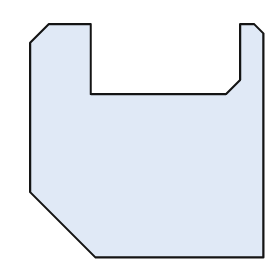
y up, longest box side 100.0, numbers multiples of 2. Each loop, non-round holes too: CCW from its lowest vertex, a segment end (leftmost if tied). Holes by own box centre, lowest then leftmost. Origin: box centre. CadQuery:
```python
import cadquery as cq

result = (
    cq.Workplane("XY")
    .moveTo(-22.0, -50.0)
    .lineTo(50.0, -50.0)
    .lineTo(50.0, 46.0)
    .lineTo(46.0, 50.0)
    .lineTo(40.0, 50.0)
    .lineTo(40.0, 26.0)
    .lineTo(34.0, 20.0)
    .lineTo(-24.0, 20.0)
    .lineTo(-24.0, 50.0)
    .lineTo(-42.0, 50.0)
    .lineTo(-50.0, 42.0)
    .lineTo(-50.0, -22.0)
    .close()
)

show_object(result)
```